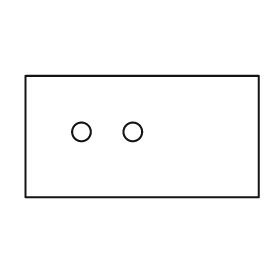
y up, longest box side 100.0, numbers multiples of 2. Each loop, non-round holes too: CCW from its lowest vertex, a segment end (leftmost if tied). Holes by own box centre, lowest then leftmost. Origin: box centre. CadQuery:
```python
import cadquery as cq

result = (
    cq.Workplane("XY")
    .moveTo(-50.0, -26.0)
    .lineTo(50.0, -26.0)
    .lineTo(50.0, 26.0)
    .lineTo(-50.0, 26.0)
    .close()
    .moveTo(-26.0, 2.0)
    .circle(4.0)
    .moveTo(-4.0, 2.0)
    .circle(4.0)
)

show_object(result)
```